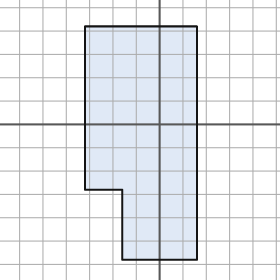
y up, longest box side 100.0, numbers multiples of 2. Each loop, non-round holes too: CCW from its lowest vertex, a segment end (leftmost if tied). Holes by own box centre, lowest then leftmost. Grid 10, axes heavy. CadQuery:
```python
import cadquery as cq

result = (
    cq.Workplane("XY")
    .moveTo(-16.0, -58.0)
    .lineTo(16.0, -58.0)
    .lineTo(16.0, 42.0)
    .lineTo(-32.0, 42.0)
    .lineTo(-32.0, -28.0)
    .lineTo(-16.0, -28.0)
    .close()
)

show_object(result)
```